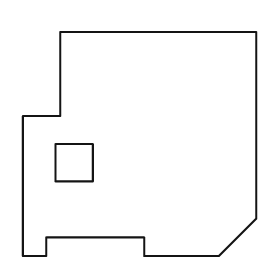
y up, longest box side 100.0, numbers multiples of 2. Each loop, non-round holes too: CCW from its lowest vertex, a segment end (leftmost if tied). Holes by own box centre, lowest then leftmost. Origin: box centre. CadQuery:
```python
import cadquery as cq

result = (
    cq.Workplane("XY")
    .moveTo(-50.0, -48.0)
    .lineTo(-40.0, -48.0)
    .lineTo(-40.0, -40.0)
    .lineTo(2.0, -40.0)
    .lineTo(2.0, -48.0)
    .lineTo(34.0, -48.0)
    .lineTo(50.0, -32.0)
    .lineTo(50.0, 48.0)
    .lineTo(-34.0, 48.0)
    .lineTo(-34.0, 12.0)
    .lineTo(-50.0, 12.0)
    .close()
    .moveTo(-36.0, -16.0)
    .lineTo(-20.0, -16.0)
    .lineTo(-20.0, 0.0)
    .lineTo(-36.0, 0.0)
    .close()
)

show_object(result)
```